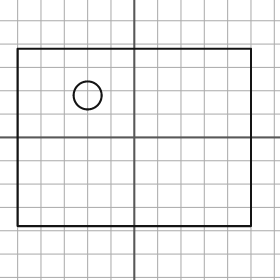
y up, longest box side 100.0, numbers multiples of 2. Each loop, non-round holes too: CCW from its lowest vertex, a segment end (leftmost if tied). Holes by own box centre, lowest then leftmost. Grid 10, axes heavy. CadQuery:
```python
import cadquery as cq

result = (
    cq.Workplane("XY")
    .moveTo(-50.0, -38.0)
    .lineTo(50.0, -38.0)
    .lineTo(50.0, 38.0)
    .lineTo(-50.0, 38.0)
    .close()
    .moveTo(-20.0, 18.0)
    .circle(6.0)
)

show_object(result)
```